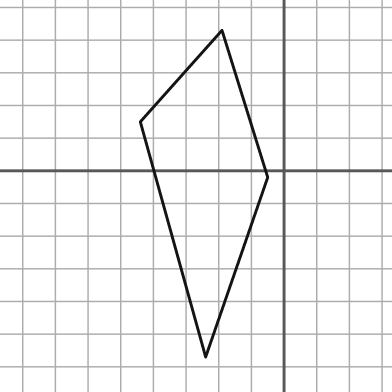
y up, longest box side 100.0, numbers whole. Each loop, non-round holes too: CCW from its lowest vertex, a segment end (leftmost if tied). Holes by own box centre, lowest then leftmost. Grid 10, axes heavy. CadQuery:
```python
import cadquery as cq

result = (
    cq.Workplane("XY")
    .moveTo(-24.0, -57.0)
    .lineTo(-5.0, -2.0)
    .lineTo(-19.0, 43.0)
    .lineTo(-44.0, 15.0)
    .close()
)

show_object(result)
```